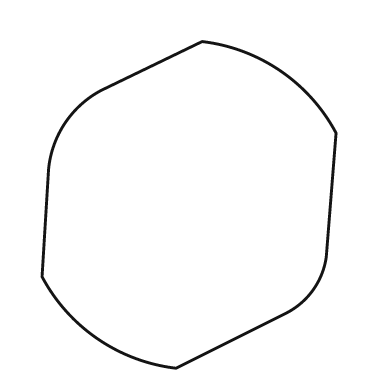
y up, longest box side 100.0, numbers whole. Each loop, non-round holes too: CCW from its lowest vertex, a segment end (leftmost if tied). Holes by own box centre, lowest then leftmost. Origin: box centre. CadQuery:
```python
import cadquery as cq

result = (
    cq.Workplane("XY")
    .moveTo(-4.0, -50.0)
    .lineTo(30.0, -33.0)
    .threePointArc((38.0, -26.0), (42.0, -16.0))
    .lineTo(45.0, 22.0)
    .threePointArc((28.0, 41.0), (4.0, 50.0))
    .lineTo(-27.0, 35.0)
    .threePointArc((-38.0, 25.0), (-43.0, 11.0))
    .lineTo(-45.0, -22.0)
    .threePointArc((-28.0, -41.0), (-4.0, -50.0))
    .close()
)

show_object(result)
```